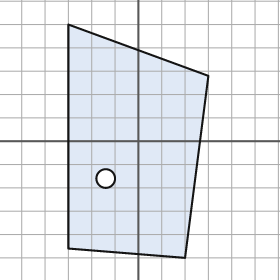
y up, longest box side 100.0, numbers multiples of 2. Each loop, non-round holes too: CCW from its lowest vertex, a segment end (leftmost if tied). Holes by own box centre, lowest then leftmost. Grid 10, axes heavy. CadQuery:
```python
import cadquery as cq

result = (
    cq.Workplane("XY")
    .moveTo(20.0, -50.0)
    .lineTo(30.0, 28.0)
    .lineTo(-30.0, 50.0)
    .lineTo(-30.0, -46.0)
    .close()
    .moveTo(-14.0, -16.0)
    .circle(4.0)
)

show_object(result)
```